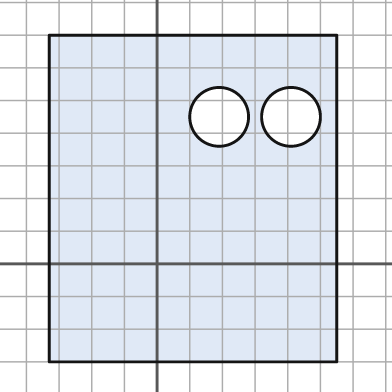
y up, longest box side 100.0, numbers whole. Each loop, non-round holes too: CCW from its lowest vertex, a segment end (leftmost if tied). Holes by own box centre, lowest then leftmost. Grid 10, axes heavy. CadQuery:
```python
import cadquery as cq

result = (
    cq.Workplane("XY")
    .moveTo(-33.0, -30.0)
    .lineTo(55.0, -30.0)
    .lineTo(55.0, 70.0)
    .lineTo(-33.0, 70.0)
    .close()
    .moveTo(19.0, 45.0)
    .circle(9.0)
    .moveTo(41.0, 45.0)
    .circle(9.0)
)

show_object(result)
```